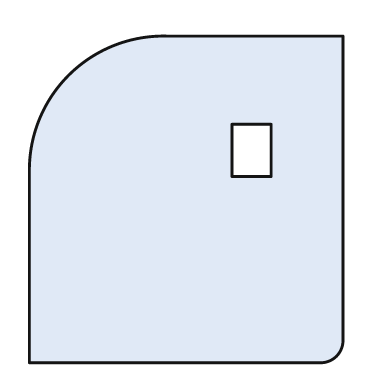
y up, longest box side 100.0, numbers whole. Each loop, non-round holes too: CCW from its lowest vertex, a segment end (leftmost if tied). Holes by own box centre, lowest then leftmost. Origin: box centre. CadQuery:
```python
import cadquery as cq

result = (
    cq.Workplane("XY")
    .moveTo(-48.0, -50.0)
    .lineTo(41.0, -50.0)
    .threePointArc((46.0, -48.0), (48.0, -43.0))
    .lineTo(48.0, 50.0)
    .lineTo(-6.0, 50.0)
    .threePointArc((-36.0, 38.0), (-48.0, 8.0))
    .close()
    .moveTo(14.0, 7.0)
    .lineTo(26.0, 7.0)
    .lineTo(26.0, 23.0)
    .lineTo(14.0, 23.0)
    .close()
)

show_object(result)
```